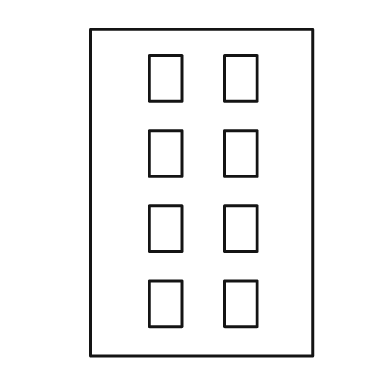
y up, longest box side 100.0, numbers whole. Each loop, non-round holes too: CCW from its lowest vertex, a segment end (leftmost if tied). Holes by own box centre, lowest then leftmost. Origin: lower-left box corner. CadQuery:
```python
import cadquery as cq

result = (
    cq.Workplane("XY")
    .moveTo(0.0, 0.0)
    .lineTo(68.0, 0.0)
    .lineTo(68.0, 100.0)
    .lineTo(0.0, 100.0)
    .close()
    .moveTo(18.0, 9.0)
    .lineTo(28.0, 9.0)
    .lineTo(28.0, 23.0)
    .lineTo(18.0, 23.0)
    .close()
    .moveTo(41.0, 9.0)
    .lineTo(51.0, 9.0)
    .lineTo(51.0, 23.0)
    .lineTo(41.0, 23.0)
    .close()
    .moveTo(18.0, 32.0)
    .lineTo(28.0, 32.0)
    .lineTo(28.0, 46.0)
    .lineTo(18.0, 46.0)
    .close()
    .moveTo(41.0, 32.0)
    .lineTo(51.0, 32.0)
    .lineTo(51.0, 46.0)
    .lineTo(41.0, 46.0)
    .close()
    .moveTo(18.0, 55.0)
    .lineTo(28.0, 55.0)
    .lineTo(28.0, 69.0)
    .lineTo(18.0, 69.0)
    .close()
    .moveTo(41.0, 55.0)
    .lineTo(51.0, 55.0)
    .lineTo(51.0, 69.0)
    .lineTo(41.0, 69.0)
    .close()
    .moveTo(18.0, 78.0)
    .lineTo(28.0, 78.0)
    .lineTo(28.0, 92.0)
    .lineTo(18.0, 92.0)
    .close()
    .moveTo(41.0, 78.0)
    .lineTo(51.0, 78.0)
    .lineTo(51.0, 92.0)
    .lineTo(41.0, 92.0)
    .close()
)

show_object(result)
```